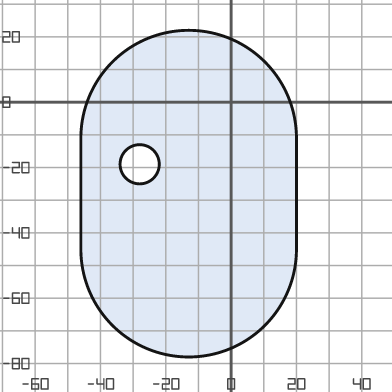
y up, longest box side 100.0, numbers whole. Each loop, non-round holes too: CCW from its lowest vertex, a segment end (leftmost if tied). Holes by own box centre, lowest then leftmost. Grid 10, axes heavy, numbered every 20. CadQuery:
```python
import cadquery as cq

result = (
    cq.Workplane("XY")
    .moveTo(-46.0, -45.0)
    .threePointArc((-13.0, -78.0), (20.0, -45.0))
    .lineTo(20.0, -11.0)
    .threePointArc((-13.0, 22.0), (-46.0, -11.0))
    .close()
    .moveTo(-28.0, -19.0)
    .circle(6.0)
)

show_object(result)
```